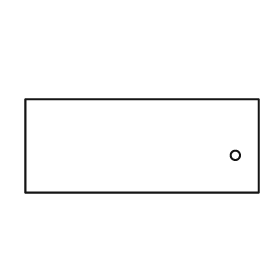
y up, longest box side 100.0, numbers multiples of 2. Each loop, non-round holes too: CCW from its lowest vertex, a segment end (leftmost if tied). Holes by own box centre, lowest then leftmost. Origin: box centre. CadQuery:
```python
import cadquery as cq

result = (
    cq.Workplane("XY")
    .moveTo(-50.0, -20.0)
    .lineTo(50.0, -20.0)
    .lineTo(50.0, 20.0)
    .lineTo(-50.0, 20.0)
    .close()
    .moveTo(40.0, -4.0)
    .circle(2.0)
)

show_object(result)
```